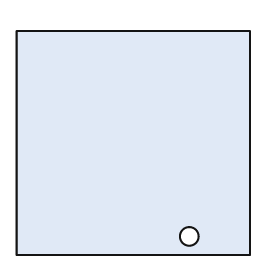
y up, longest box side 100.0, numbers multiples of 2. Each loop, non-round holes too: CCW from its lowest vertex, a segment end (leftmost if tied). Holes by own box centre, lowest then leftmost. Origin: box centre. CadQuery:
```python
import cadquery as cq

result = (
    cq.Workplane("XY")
    .moveTo(-50.0, -48.0)
    .lineTo(50.0, -48.0)
    .lineTo(50.0, 48.0)
    .lineTo(-50.0, 48.0)
    .close()
    .moveTo(24.0, -40.0)
    .circle(4.0)
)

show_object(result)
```